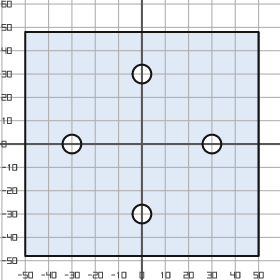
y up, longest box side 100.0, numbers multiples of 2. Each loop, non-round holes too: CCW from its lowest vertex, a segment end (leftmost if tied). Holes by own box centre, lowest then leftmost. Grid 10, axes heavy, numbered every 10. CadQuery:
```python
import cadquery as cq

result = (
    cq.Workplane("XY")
    .moveTo(-50.0, -48.0)
    .lineTo(50.0, -48.0)
    .lineTo(50.0, 48.0)
    .lineTo(-50.0, 48.0)
    .close()
    .moveTo(0.0, -30.0)
    .circle(4.0)
    .moveTo(-30.0, 0.0)
    .circle(4.0)
    .moveTo(30.0, 0.0)
    .circle(4.0)
    .moveTo(0.0, 30.0)
    .circle(4.0)
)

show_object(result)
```